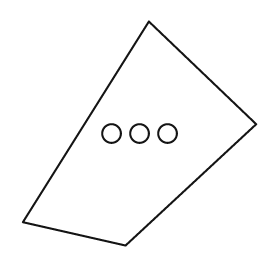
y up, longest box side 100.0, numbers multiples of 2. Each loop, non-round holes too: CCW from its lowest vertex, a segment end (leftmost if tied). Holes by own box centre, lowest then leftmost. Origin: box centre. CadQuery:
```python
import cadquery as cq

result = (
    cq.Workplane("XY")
    .moveTo(-6.0, -48.0)
    .lineTo(50.0, 4.0)
    .lineTo(4.0, 48.0)
    .lineTo(-50.0, -38.0)
    .close()
    .moveTo(-12.0, 0.0)
    .circle(4.0)
    .moveTo(0.0, 0.0)
    .circle(4.0)
    .moveTo(12.0, 0.0)
    .circle(4.0)
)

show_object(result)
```